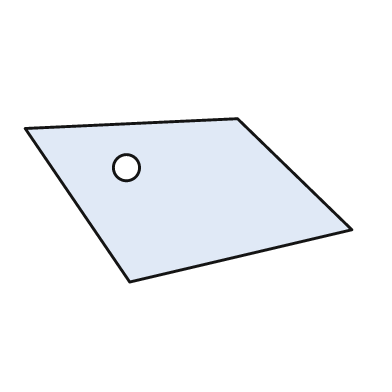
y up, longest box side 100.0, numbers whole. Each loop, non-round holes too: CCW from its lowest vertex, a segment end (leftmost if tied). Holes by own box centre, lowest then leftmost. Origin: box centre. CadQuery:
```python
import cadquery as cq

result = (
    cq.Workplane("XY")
    .moveTo(-18.0, -25.0)
    .lineTo(50.0, -9.0)
    .lineTo(15.0, 25.0)
    .lineTo(-50.0, 22.0)
    .close()
    .moveTo(-19.0, 10.0)
    .circle(4.0)
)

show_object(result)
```